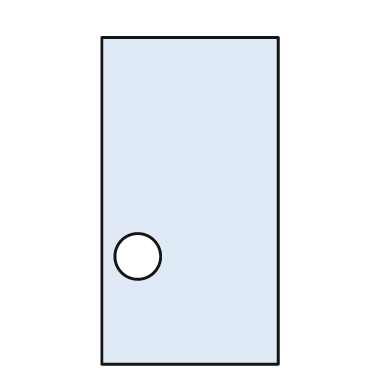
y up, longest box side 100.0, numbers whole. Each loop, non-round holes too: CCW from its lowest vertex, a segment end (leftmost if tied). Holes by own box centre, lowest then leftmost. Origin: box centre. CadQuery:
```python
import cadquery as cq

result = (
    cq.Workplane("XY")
    .moveTo(-27.0, -50.0)
    .lineTo(27.0, -50.0)
    .lineTo(27.0, 50.0)
    .lineTo(-27.0, 50.0)
    .close()
    .moveTo(-16.0, -17.0)
    .circle(7.0)
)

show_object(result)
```